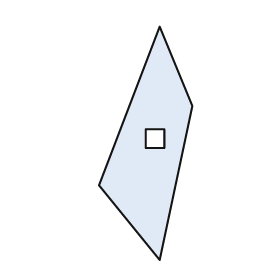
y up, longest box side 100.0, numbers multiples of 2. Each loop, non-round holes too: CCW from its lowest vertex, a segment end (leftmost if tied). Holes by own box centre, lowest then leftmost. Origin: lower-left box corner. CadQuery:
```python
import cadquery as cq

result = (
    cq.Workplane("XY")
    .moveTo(26.0, 0.0)
    .lineTo(40.0, 66.0)
    .lineTo(26.0, 100.0)
    .lineTo(0.0, 32.0)
    .close()
    .moveTo(20.0, 48.0)
    .lineTo(28.0, 48.0)
    .lineTo(28.0, 56.0)
    .lineTo(20.0, 56.0)
    .close()
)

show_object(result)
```